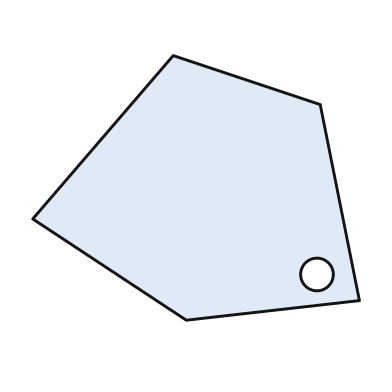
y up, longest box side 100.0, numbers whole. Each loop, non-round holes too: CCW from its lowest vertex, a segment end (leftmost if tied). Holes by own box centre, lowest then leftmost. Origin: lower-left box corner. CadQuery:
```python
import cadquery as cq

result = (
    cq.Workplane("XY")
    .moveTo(47.0, 0.0)
    .lineTo(100.0, 6.0)
    .lineTo(88.0, 66.0)
    .lineTo(43.0, 81.0)
    .lineTo(0.0, 31.0)
    .close()
    .moveTo(87.0, 14.0)
    .circle(5.0)
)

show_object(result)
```